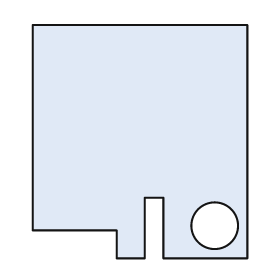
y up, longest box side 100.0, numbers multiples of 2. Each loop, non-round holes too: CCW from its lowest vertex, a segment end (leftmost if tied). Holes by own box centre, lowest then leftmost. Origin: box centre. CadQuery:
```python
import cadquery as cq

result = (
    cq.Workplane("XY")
    .moveTo(-10.0, -50.0)
    .lineTo(2.0, -50.0)
    .lineTo(2.0, -24.0)
    .lineTo(10.0, -24.0)
    .lineTo(10.0, -50.0)
    .lineTo(46.0, -50.0)
    .lineTo(46.0, 50.0)
    .lineTo(-46.0, 50.0)
    .lineTo(-46.0, -38.0)
    .lineTo(-10.0, -38.0)
    .close()
    .moveTo(32.0, -36.0)
    .circle(10.0)
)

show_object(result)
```